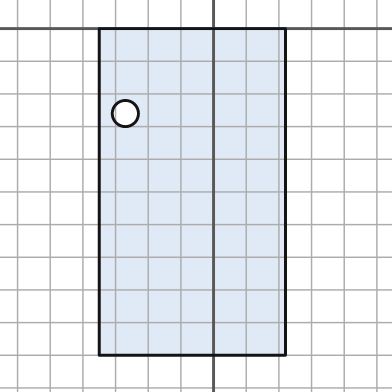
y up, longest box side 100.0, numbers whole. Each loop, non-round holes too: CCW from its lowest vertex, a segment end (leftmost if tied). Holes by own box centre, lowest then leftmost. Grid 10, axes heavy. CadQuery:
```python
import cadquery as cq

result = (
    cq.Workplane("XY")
    .moveTo(-35.0, -100.0)
    .lineTo(22.0, -100.0)
    .lineTo(22.0, 0.0)
    .lineTo(-35.0, 0.0)
    .close()
    .moveTo(-27.0, -26.0)
    .circle(4.0)
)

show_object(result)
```